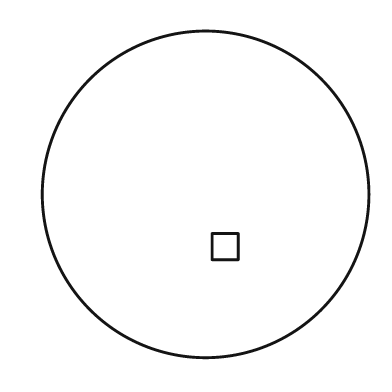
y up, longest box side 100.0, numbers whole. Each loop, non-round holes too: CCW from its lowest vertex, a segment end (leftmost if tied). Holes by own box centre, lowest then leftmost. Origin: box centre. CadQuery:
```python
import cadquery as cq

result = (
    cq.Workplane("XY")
    .moveTo(0.0, 0.0)
    .circle(50.0)
    .moveTo(2.0, -20.0)
    .lineTo(10.0, -20.0)
    .lineTo(10.0, -12.0)
    .lineTo(2.0, -12.0)
    .close()
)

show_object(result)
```